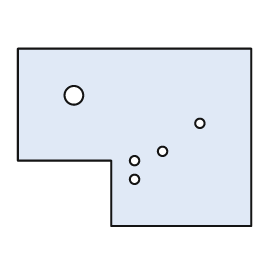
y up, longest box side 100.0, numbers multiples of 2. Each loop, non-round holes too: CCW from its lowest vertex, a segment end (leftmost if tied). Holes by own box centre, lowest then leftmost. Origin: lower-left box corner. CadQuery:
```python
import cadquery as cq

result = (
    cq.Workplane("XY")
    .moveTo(40.0, 0.0)
    .lineTo(100.0, 0.0)
    .lineTo(100.0, 76.0)
    .lineTo(0.0, 76.0)
    .lineTo(0.0, 28.0)
    .lineTo(40.0, 28.0)
    .close()
    .moveTo(50.0, 20.0)
    .circle(2.0)
    .moveTo(50.0, 28.0)
    .circle(2.0)
    .moveTo(62.0, 32.0)
    .circle(2.0)
    .moveTo(78.0, 44.0)
    .circle(2.0)
    .moveTo(24.0, 56.0)
    .circle(4.0)
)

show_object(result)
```